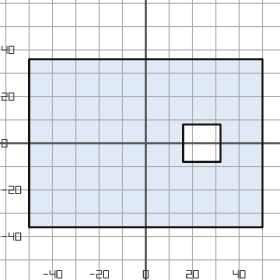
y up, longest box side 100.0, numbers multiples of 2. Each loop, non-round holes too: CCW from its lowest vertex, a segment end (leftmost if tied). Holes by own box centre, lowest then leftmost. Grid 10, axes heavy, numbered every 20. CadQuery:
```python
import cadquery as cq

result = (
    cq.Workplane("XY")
    .moveTo(-50.0, -36.0)
    .lineTo(50.0, -36.0)
    .lineTo(50.0, 36.0)
    .lineTo(-50.0, 36.0)
    .close()
    .moveTo(16.0, -8.0)
    .lineTo(32.0, -8.0)
    .lineTo(32.0, 8.0)
    .lineTo(16.0, 8.0)
    .close()
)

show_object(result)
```